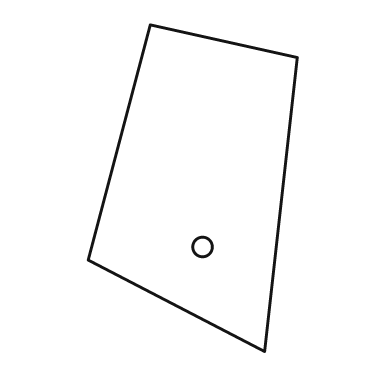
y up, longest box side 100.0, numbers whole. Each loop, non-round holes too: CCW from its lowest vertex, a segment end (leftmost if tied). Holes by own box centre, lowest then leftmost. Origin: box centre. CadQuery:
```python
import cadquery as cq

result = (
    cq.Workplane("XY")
    .moveTo(22.0, -50.0)
    .lineTo(32.0, 40.0)
    .lineTo(-13.0, 50.0)
    .lineTo(-32.0, -22.0)
    .close()
    .moveTo(3.0, -18.0)
    .circle(3.0)
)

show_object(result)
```